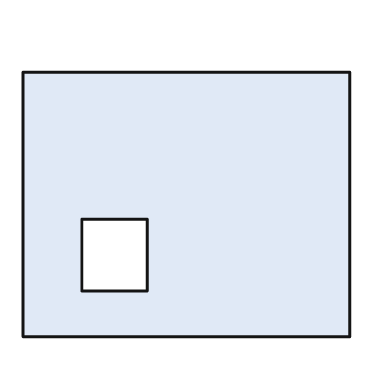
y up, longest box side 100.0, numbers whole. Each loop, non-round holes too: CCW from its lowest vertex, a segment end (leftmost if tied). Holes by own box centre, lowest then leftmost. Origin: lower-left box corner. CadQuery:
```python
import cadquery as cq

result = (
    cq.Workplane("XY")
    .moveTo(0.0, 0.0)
    .lineTo(100.0, 0.0)
    .lineTo(100.0, 81.0)
    .lineTo(0.0, 81.0)
    .close()
    .moveTo(18.0, 14.0)
    .lineTo(38.0, 14.0)
    .lineTo(38.0, 36.0)
    .lineTo(18.0, 36.0)
    .close()
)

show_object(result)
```